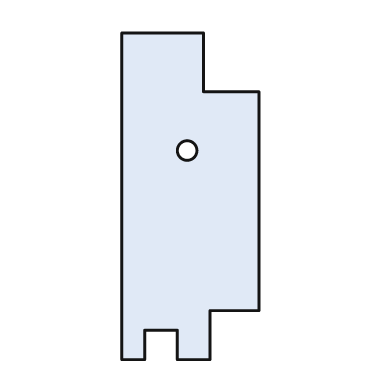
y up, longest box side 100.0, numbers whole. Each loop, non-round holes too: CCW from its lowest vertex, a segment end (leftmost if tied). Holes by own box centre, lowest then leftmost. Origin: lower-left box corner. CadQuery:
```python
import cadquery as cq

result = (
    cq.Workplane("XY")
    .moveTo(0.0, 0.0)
    .lineTo(7.0, 0.0)
    .lineTo(7.0, 9.0)
    .lineTo(17.0, 9.0)
    .lineTo(17.0, 0.0)
    .lineTo(27.0, 0.0)
    .lineTo(27.0, 15.0)
    .lineTo(42.0, 15.0)
    .lineTo(42.0, 82.0)
    .lineTo(25.0, 82.0)
    .lineTo(25.0, 100.0)
    .lineTo(0.0, 100.0)
    .close()
    .moveTo(20.0, 64.0)
    .circle(3.0)
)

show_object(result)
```